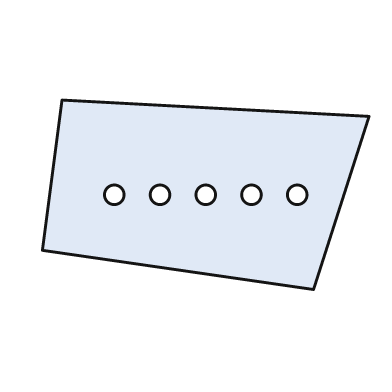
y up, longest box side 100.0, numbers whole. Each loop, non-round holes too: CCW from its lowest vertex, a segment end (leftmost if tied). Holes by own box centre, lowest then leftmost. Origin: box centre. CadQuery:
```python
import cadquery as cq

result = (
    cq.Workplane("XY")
    .moveTo(33.0, -29.0)
    .lineTo(50.0, 24.0)
    .lineTo(-44.0, 29.0)
    .lineTo(-50.0, -17.0)
    .close()
    .moveTo(-28.0, 0.0)
    .circle(3.0)
    .moveTo(-14.0, 0.0)
    .circle(3.0)
    .moveTo(0.0, 0.0)
    .circle(3.0)
    .moveTo(14.0, 0.0)
    .circle(3.0)
    .moveTo(28.0, 0.0)
    .circle(3.0)
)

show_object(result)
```